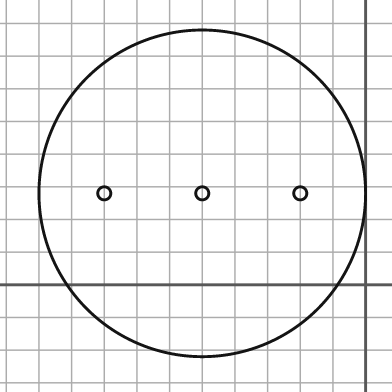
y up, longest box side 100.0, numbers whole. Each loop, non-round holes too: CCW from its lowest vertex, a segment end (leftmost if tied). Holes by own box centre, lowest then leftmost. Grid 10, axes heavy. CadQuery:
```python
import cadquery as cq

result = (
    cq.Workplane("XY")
    .moveTo(-50.0, 28.0)
    .circle(50.0)
    .moveTo(-80.0, 28.0)
    .circle(2.0)
    .moveTo(-50.0, 28.0)
    .circle(2.0)
    .moveTo(-20.0, 28.0)
    .circle(2.0)
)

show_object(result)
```